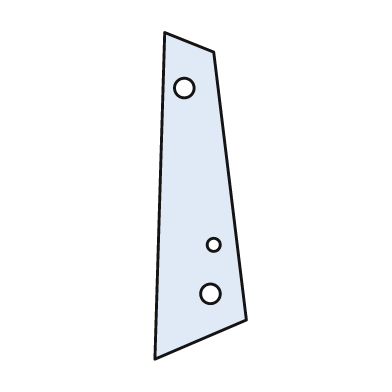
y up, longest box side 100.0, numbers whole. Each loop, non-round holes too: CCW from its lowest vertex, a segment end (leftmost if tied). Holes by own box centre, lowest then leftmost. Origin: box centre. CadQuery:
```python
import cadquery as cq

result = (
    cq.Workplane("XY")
    .moveTo(-14.0, -50.0)
    .lineTo(14.0, -38.0)
    .lineTo(4.0, 44.0)
    .lineTo(-11.0, 50.0)
    .close()
    .moveTo(3.0, -30.0)
    .circle(3.0)
    .moveTo(4.0, -15.0)
    .circle(2.0)
    .moveTo(-5.0, 33.0)
    .circle(3.0)
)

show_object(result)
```